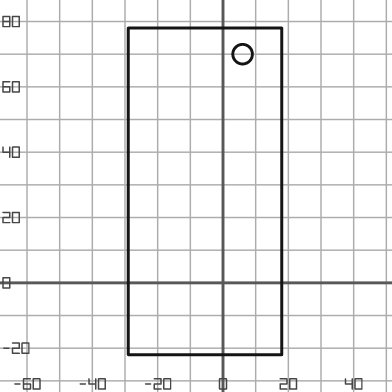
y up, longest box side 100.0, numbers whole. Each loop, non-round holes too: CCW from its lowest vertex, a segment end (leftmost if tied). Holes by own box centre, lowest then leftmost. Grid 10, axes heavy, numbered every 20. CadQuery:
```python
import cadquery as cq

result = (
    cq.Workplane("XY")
    .moveTo(-29.0, -22.0)
    .lineTo(18.0, -22.0)
    .lineTo(18.0, 78.0)
    .lineTo(-29.0, 78.0)
    .close()
    .moveTo(6.0, 70.0)
    .circle(3.0)
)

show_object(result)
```